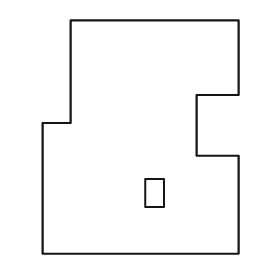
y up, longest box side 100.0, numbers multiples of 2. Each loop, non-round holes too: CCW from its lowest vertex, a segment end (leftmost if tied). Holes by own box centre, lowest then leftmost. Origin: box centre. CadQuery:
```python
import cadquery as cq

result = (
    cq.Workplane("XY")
    .moveTo(-42.0, -50.0)
    .lineTo(42.0, -50.0)
    .lineTo(42.0, -8.0)
    .lineTo(24.0, -8.0)
    .lineTo(24.0, 18.0)
    .lineTo(42.0, 18.0)
    .lineTo(42.0, 50.0)
    .lineTo(-30.0, 50.0)
    .lineTo(-30.0, 6.0)
    .lineTo(-42.0, 6.0)
    .close()
    .moveTo(2.0, -30.0)
    .lineTo(10.0, -30.0)
    .lineTo(10.0, -18.0)
    .lineTo(2.0, -18.0)
    .close()
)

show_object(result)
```